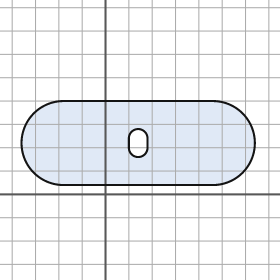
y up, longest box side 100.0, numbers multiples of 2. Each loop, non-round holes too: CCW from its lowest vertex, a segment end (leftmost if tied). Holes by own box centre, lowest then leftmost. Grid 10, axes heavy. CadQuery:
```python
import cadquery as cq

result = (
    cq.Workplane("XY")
    .moveTo(-18.0, 4.0)
    .lineTo(46.0, 4.0)
    .threePointArc((64.0, 22.0), (46.0, 40.0))
    .lineTo(-18.0, 40.0)
    .threePointArc((-36.0, 22.0), (-18.0, 4.0))
    .close()
    .moveTo(10.0, 20.0)
    .threePointArc((14.0, 16.0), (18.0, 20.0))
    .lineTo(18.0, 24.0)
    .threePointArc((14.0, 28.0), (10.0, 24.0))
    .close()
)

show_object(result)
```